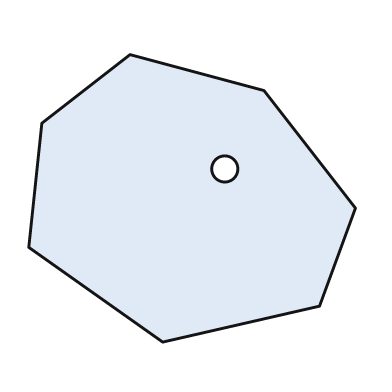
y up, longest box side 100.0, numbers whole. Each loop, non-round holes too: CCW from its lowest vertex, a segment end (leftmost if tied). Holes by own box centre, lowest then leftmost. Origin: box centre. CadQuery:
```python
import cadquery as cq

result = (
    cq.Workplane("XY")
    .moveTo(-9.0, -44.0)
    .lineTo(39.0, -33.0)
    .lineTo(50.0, -3.0)
    .lineTo(22.0, 33.0)
    .lineTo(-19.0, 44.0)
    .lineTo(-46.0, 23.0)
    .lineTo(-50.0, -15.0)
    .close()
    .moveTo(10.0, 9.0)
    .circle(4.0)
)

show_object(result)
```